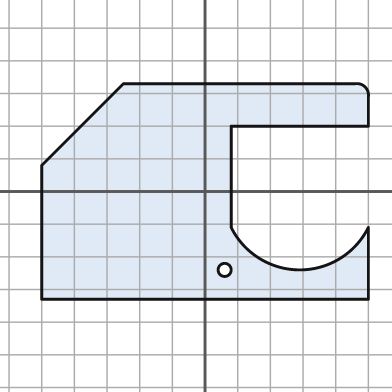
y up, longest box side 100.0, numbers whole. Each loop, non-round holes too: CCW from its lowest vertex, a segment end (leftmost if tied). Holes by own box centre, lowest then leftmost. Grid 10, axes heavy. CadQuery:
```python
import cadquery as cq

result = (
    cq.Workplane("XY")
    .moveTo(-50.0, -33.0)
    .lineTo(50.0, -33.0)
    .lineTo(50.0, -11.0)
    .threePointArc((29.0, -24.0), (8.0, -11.0))
    .lineTo(8.0, 20.0)
    .lineTo(50.0, 20.0)
    .lineTo(50.0, 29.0)
    .threePointArc((49.0, 32.0), (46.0, 33.0))
    .lineTo(-25.0, 33.0)
    .lineTo(-50.0, 8.0)
    .close()
    .moveTo(6.0, -24.0)
    .circle(2.0)
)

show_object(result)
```